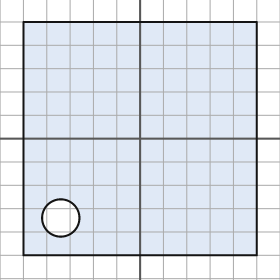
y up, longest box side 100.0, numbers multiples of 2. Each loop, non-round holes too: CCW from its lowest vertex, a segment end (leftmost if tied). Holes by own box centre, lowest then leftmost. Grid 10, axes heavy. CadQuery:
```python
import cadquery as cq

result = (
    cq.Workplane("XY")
    .moveTo(-50.0, -50.0)
    .lineTo(50.0, -50.0)
    .lineTo(50.0, 50.0)
    .lineTo(-50.0, 50.0)
    .close()
    .moveTo(-34.0, -34.0)
    .circle(8.0)
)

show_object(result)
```